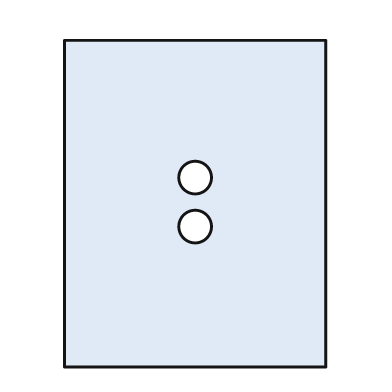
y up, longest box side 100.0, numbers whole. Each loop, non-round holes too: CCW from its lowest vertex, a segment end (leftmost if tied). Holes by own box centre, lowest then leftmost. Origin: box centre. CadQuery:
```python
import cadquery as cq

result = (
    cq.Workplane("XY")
    .moveTo(-40.0, -50.0)
    .lineTo(40.0, -50.0)
    .lineTo(40.0, 50.0)
    .lineTo(-40.0, 50.0)
    .close()
    .moveTo(0.0, -7.0)
    .circle(5.0)
    .moveTo(0.0, 8.0)
    .circle(5.0)
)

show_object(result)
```